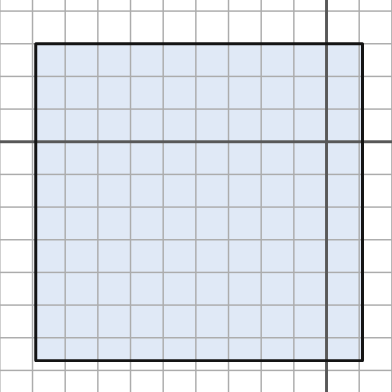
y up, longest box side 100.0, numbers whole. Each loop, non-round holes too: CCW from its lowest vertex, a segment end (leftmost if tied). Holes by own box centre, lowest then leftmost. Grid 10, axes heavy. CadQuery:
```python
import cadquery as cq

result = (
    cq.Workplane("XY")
    .moveTo(-89.0, -67.0)
    .lineTo(11.0, -67.0)
    .lineTo(11.0, 30.0)
    .lineTo(-89.0, 30.0)
    .close()
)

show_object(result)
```